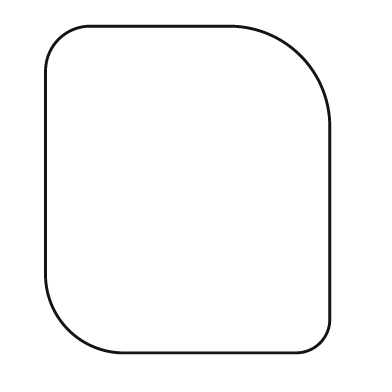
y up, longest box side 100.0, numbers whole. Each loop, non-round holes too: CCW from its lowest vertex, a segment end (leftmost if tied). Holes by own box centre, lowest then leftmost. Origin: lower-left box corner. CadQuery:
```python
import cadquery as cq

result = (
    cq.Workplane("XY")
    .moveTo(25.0, 0.0)
    .lineTo(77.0, 0.0)
    .threePointArc((84.0, 3.0), (87.0, 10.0))
    .lineTo(87.0, 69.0)
    .threePointArc((78.0, 91.0), (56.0, 100.0))
    .lineTo(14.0, 100.0)
    .threePointArc((4.0, 96.0), (0.0, 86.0))
    .lineTo(0.0, 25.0)
    .threePointArc((7.0, 7.0), (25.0, 0.0))
    .close()
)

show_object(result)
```